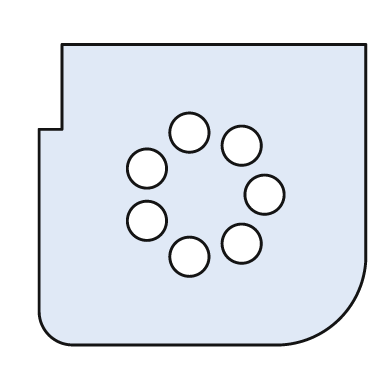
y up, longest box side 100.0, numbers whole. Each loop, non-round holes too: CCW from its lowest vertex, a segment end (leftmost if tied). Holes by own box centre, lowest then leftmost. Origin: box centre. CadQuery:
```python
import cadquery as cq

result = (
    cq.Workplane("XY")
    .moveTo(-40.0, -46.0)
    .lineTo(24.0, -46.0)
    .threePointArc((42.0, -38.0), (50.0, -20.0))
    .lineTo(50.0, 46.0)
    .lineTo(-43.0, 46.0)
    .lineTo(-43.0, 20.0)
    .lineTo(-50.0, 20.0)
    .lineTo(-50.0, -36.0)
    .threePointArc((-47.0, -43.0), (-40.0, -46.0))
    .close()
    .moveTo(-4.0, -19.0)
    .circle(6.0)
    .moveTo(12.0, -15.0)
    .circle(6.0)
    .moveTo(-17.0, -8.0)
    .circle(6.0)
    .moveTo(19.0, 0.0)
    .circle(6.0)
    .moveTo(-17.0, 8.0)
    .circle(6.0)
    .moveTo(12.0, 15.0)
    .circle(6.0)
    .moveTo(-4.0, 19.0)
    .circle(6.0)
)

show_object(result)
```